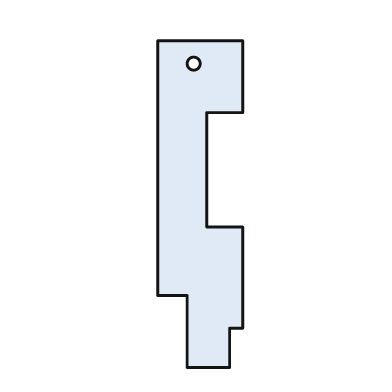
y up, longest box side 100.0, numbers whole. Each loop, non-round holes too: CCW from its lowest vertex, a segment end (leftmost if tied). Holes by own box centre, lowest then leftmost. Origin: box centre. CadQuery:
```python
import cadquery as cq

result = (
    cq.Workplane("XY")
    .moveTo(-4.0, -50.0)
    .lineTo(9.0, -50.0)
    .lineTo(9.0, -38.0)
    .lineTo(13.0, -38.0)
    .lineTo(13.0, -7.0)
    .lineTo(2.0, -7.0)
    .lineTo(2.0, 28.0)
    .lineTo(13.0, 28.0)
    .lineTo(13.0, 50.0)
    .lineTo(-13.0, 50.0)
    .lineTo(-13.0, -28.0)
    .lineTo(-4.0, -28.0)
    .close()
    .moveTo(-2.0, 43.0)
    .circle(2.0)
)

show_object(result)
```